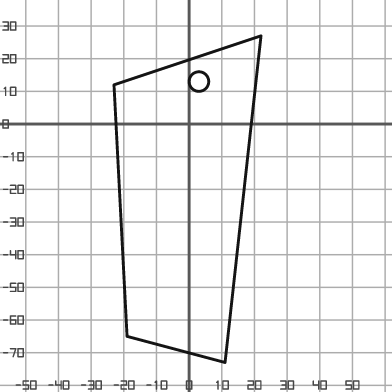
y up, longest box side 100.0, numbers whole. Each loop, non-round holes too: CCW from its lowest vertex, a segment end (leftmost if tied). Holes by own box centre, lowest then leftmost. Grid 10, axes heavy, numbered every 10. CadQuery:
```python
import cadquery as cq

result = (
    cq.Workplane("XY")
    .moveTo(11.0, -73.0)
    .lineTo(22.0, 27.0)
    .lineTo(-23.0, 12.0)
    .lineTo(-19.0, -65.0)
    .close()
    .moveTo(3.0, 13.0)
    .circle(3.0)
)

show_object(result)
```